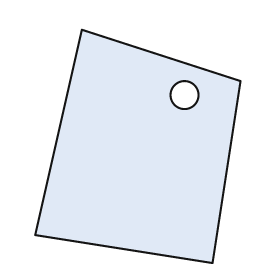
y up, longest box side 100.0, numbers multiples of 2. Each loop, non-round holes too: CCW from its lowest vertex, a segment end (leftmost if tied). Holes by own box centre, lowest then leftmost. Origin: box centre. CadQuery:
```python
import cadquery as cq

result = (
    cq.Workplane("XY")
    .moveTo(32.0, -50.0)
    .lineTo(44.0, 28.0)
    .lineTo(-24.0, 50.0)
    .lineTo(-44.0, -38.0)
    .close()
    .moveTo(20.0, 22.0)
    .circle(6.0)
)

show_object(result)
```